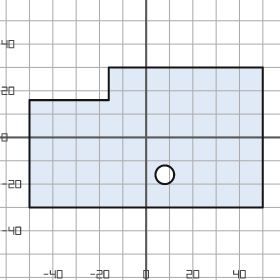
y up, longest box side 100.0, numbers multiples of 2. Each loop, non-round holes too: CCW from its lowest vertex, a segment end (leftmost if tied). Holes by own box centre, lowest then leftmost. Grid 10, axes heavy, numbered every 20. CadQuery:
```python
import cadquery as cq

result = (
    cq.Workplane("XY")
    .moveTo(-50.0, -30.0)
    .lineTo(50.0, -30.0)
    .lineTo(50.0, 30.0)
    .lineTo(-16.0, 30.0)
    .lineTo(-16.0, 16.0)
    .lineTo(-50.0, 16.0)
    .close()
    .moveTo(8.0, -16.0)
    .circle(4.0)
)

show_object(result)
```